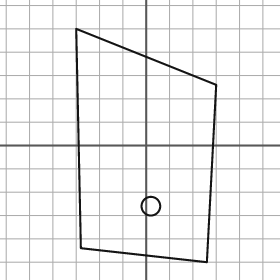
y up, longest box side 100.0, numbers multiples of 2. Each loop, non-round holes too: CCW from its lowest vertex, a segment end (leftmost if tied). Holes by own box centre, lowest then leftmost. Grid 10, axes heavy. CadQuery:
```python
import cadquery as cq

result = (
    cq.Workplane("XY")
    .moveTo(26.0, -50.0)
    .lineTo(30.0, 26.0)
    .lineTo(-30.0, 50.0)
    .lineTo(-28.0, -44.0)
    .close()
    .moveTo(2.0, -26.0)
    .circle(4.0)
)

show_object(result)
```